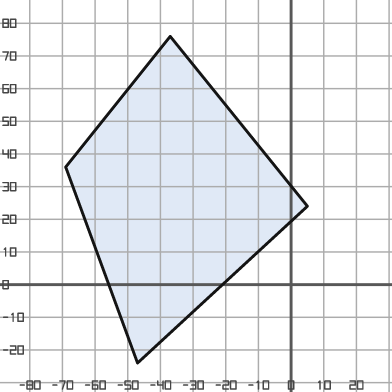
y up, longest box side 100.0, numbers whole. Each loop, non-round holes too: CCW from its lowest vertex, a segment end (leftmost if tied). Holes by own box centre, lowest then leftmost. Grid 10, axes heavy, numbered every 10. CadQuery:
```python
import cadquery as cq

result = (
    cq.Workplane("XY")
    .moveTo(-47.0, -24.0)
    .lineTo(5.0, 24.0)
    .lineTo(-37.0, 76.0)
    .lineTo(-69.0, 36.0)
    .close()
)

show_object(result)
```